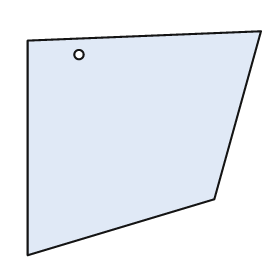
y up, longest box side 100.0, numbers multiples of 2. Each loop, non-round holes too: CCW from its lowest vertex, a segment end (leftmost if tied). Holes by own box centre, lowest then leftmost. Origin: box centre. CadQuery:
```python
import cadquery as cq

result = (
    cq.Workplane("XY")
    .moveTo(-50.0, -48.0)
    .lineTo(30.0, -24.0)
    .lineTo(50.0, 48.0)
    .lineTo(-50.0, 44.0)
    .close()
    .moveTo(-28.0, 38.0)
    .circle(2.0)
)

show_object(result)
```